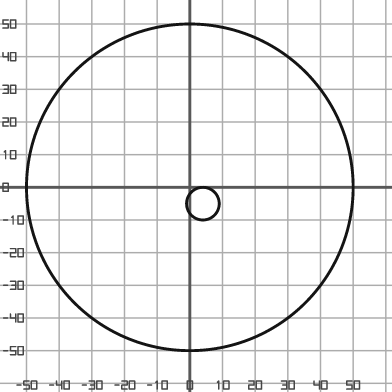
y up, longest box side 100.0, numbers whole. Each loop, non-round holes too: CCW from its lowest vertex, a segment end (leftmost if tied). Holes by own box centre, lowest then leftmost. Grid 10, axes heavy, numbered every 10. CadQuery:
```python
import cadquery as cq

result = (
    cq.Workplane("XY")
    .moveTo(0.0, 0.0)
    .circle(50.0)
    .moveTo(4.0, -5.0)
    .circle(5.0)
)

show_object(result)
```